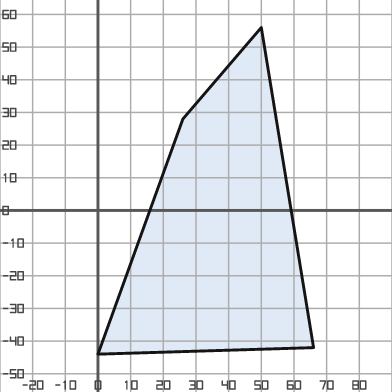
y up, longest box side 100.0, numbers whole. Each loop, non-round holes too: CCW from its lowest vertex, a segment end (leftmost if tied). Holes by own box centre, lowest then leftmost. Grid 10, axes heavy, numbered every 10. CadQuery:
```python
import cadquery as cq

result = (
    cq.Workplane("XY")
    .moveTo(0.0, -44.0)
    .lineTo(66.0, -42.0)
    .lineTo(50.0, 56.0)
    .lineTo(26.0, 28.0)
    .close()
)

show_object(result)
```